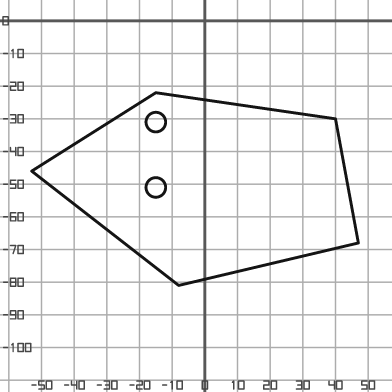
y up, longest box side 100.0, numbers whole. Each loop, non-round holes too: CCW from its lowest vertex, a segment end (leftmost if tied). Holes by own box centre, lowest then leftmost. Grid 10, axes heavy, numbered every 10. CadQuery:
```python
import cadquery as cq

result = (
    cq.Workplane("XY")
    .moveTo(-8.0, -81.0)
    .lineTo(47.0, -68.0)
    .lineTo(40.0, -30.0)
    .lineTo(-15.0, -22.0)
    .lineTo(-53.0, -46.0)
    .close()
    .moveTo(-15.0, -51.0)
    .circle(3.0)
    .moveTo(-15.0, -31.0)
    .circle(3.0)
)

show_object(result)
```